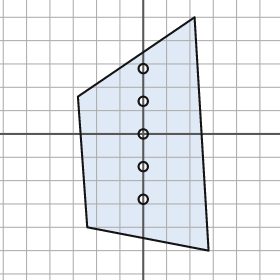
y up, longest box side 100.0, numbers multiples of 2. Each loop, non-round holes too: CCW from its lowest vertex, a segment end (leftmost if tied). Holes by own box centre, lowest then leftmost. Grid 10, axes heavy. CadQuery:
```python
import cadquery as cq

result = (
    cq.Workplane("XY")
    .moveTo(28.0, -50.0)
    .lineTo(22.0, 50.0)
    .lineTo(-28.0, 16.0)
    .lineTo(-24.0, -40.0)
    .close()
    .moveTo(0.0, -28.0)
    .circle(2.0)
    .moveTo(0.0, -14.0)
    .circle(2.0)
    .moveTo(0.0, 0.0)
    .circle(2.0)
    .moveTo(0.0, 14.0)
    .circle(2.0)
    .moveTo(0.0, 28.0)
    .circle(2.0)
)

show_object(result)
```